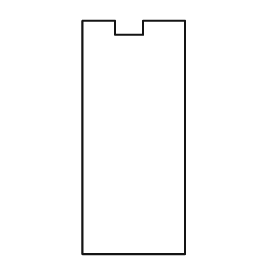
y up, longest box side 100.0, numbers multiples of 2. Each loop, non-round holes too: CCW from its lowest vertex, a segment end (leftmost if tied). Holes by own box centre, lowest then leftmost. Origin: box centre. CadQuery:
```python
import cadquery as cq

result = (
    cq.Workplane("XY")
    .moveTo(-22.0, -50.0)
    .lineTo(22.0, -50.0)
    .lineTo(22.0, 50.0)
    .lineTo(4.0, 50.0)
    .lineTo(4.0, 44.0)
    .lineTo(-8.0, 44.0)
    .lineTo(-8.0, 50.0)
    .lineTo(-22.0, 50.0)
    .close()
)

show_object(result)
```